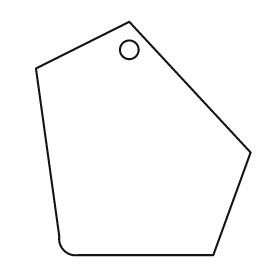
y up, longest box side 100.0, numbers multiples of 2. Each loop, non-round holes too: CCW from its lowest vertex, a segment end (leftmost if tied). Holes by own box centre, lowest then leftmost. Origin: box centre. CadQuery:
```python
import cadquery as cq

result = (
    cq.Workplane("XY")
    .moveTo(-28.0, -50.0)
    .lineTo(30.0, -50.0)
    .lineTo(46.0, -6.0)
    .lineTo(-6.0, 50.0)
    .lineTo(-46.0, 30.0)
    .lineTo(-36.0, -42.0)
    .threePointArc((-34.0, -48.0), (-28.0, -50.0))
    .close()
    .moveTo(-6.0, 38.0)
    .circle(4.0)
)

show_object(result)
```